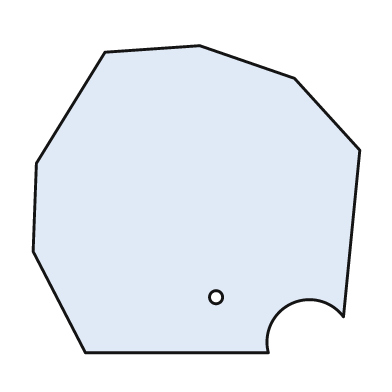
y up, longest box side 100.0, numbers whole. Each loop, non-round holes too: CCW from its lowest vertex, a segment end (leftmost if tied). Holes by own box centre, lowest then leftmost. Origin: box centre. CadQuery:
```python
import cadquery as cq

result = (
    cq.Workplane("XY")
    .moveTo(-34.0, -47.0)
    .lineTo(22.0, -47.0)
    .threePointArc((29.0, -32.0), (45.0, -36.0))
    .lineTo(50.0, 15.0)
    .lineTo(30.0, 37.0)
    .lineTo(1.0, 47.0)
    .lineTo(-28.0, 45.0)
    .lineTo(-49.0, 11.0)
    .lineTo(-50.0, -16.0)
    .close()
    .moveTo(6.0, -30.0)
    .circle(2.0)
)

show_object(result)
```